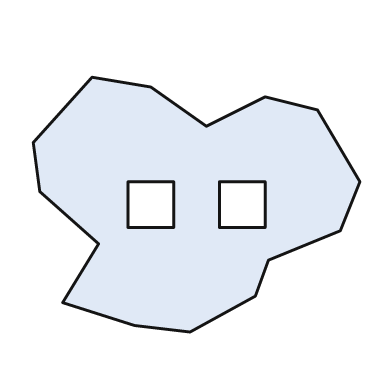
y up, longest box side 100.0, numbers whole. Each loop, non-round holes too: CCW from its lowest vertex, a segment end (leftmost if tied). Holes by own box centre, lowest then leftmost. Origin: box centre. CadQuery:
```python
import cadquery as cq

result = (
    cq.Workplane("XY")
    .moveTo(-2.0, -39.0)
    .lineTo(18.0, -28.0)
    .lineTo(22.0, -17.0)
    .lineTo(44.0, -8.0)
    .lineTo(50.0, 7.0)
    .lineTo(37.0, 29.0)
    .lineTo(21.0, 33.0)
    .lineTo(3.0, 24.0)
    .lineTo(-14.0, 36.0)
    .lineTo(-32.0, 39.0)
    .lineTo(-50.0, 19.0)
    .lineTo(-48.0, 4.0)
    .lineTo(-30.0, -12.0)
    .lineTo(-41.0, -30.0)
    .lineTo(-19.0, -37.0)
    .close()
    .moveTo(-21.0, -7.0)
    .lineTo(-7.0, -7.0)
    .lineTo(-7.0, 7.0)
    .lineTo(-21.0, 7.0)
    .close()
    .moveTo(7.0, -7.0)
    .lineTo(21.0, -7.0)
    .lineTo(21.0, 7.0)
    .lineTo(7.0, 7.0)
    .close()
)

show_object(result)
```